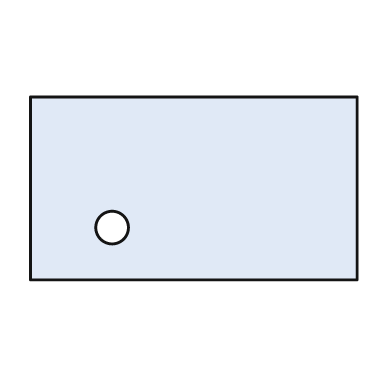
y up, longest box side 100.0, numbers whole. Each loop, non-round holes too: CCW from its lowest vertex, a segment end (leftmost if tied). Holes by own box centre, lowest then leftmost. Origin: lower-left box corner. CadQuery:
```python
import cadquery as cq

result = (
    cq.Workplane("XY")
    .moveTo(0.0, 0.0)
    .lineTo(100.0, 0.0)
    .lineTo(100.0, 56.0)
    .lineTo(0.0, 56.0)
    .close()
    .moveTo(25.0, 16.0)
    .circle(5.0)
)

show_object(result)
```